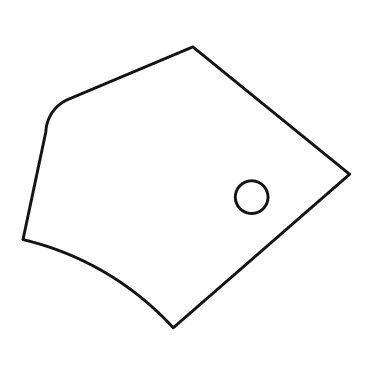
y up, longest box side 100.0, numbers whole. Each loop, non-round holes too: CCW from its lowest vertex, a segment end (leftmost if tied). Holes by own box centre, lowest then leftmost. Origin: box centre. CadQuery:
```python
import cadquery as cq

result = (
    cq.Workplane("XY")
    .moveTo(-4.0, -43.0)
    .lineTo(50.0, 4.0)
    .lineTo(2.0, 43.0)
    .lineTo(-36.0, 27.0)
    .threePointArc((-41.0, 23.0), (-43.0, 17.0))
    .lineTo(-50.0, -16.0)
    .threePointArc((-25.0, -26.0), (-4.0, -43.0))
    .close()
    .moveTo(20.0, -3.0)
    .circle(5.0)
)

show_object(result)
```